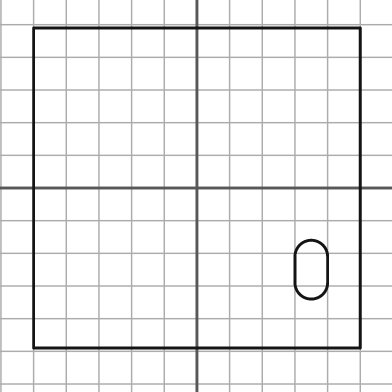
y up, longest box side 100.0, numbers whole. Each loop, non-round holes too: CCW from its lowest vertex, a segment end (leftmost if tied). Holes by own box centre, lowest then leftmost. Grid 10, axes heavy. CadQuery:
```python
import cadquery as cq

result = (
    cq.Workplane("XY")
    .moveTo(-50.0, -49.0)
    .lineTo(50.0, -49.0)
    .lineTo(50.0, 49.0)
    .lineTo(-50.0, 49.0)
    .close()
    .moveTo(30.0, -29.0)
    .threePointArc((35.0, -34.0), (40.0, -29.0))
    .lineTo(40.0, -21.0)
    .threePointArc((35.0, -16.0), (30.0, -21.0))
    .close()
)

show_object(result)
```